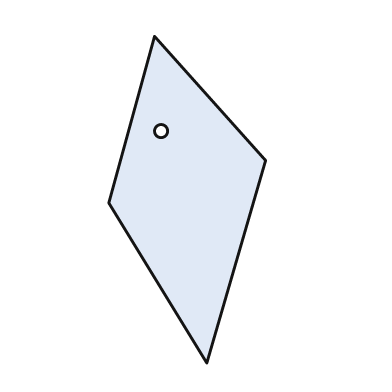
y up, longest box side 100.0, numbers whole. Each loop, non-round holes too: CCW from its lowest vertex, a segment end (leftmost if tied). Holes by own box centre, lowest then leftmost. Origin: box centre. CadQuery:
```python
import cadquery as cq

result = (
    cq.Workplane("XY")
    .moveTo(6.0, -50.0)
    .lineTo(24.0, 12.0)
    .lineTo(-10.0, 50.0)
    .lineTo(-24.0, -1.0)
    .close()
    .moveTo(-8.0, 21.0)
    .circle(2.0)
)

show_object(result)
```